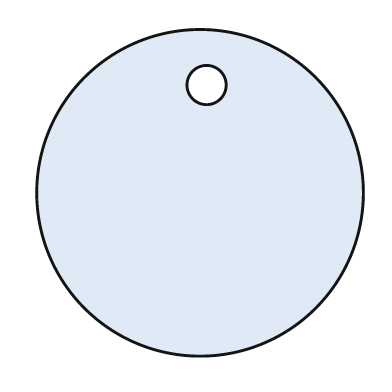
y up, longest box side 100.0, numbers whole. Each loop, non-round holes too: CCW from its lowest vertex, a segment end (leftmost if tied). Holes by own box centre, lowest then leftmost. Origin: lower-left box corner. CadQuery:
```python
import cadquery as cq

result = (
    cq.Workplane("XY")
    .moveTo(50.0, 50.0)
    .circle(50.0)
    .moveTo(52.0, 83.0)
    .circle(6.0)
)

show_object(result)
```